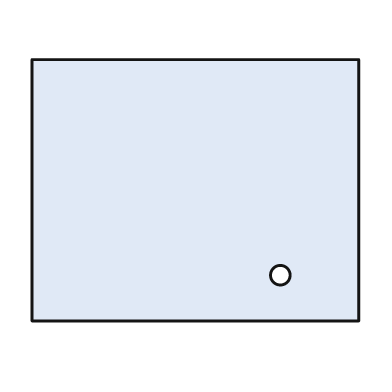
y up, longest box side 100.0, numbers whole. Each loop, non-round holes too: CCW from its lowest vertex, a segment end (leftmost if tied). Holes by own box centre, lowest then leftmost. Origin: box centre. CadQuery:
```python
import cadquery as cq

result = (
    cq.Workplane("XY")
    .moveTo(-50.0, -40.0)
    .lineTo(50.0, -40.0)
    .lineTo(50.0, 40.0)
    .lineTo(-50.0, 40.0)
    .close()
    .moveTo(26.0, -26.0)
    .circle(3.0)
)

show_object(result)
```